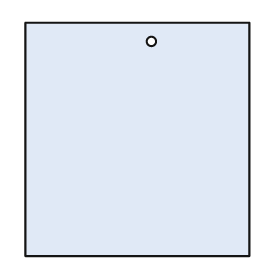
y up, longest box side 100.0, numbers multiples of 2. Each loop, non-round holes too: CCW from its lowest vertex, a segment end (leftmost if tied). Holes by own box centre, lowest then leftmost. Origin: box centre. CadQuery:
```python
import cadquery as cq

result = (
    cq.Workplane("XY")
    .moveTo(-48.0, -50.0)
    .lineTo(48.0, -50.0)
    .lineTo(48.0, 50.0)
    .lineTo(-48.0, 50.0)
    .close()
    .moveTo(6.0, 42.0)
    .circle(2.0)
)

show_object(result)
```